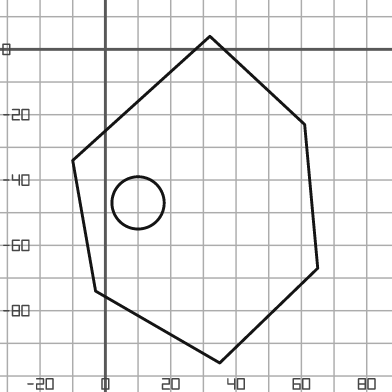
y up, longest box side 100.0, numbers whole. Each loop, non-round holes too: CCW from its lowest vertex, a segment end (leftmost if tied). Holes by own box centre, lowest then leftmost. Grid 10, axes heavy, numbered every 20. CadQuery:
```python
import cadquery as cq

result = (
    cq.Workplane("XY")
    .moveTo(35.0, -96.0)
    .lineTo(65.0, -67.0)
    .lineTo(61.0, -23.0)
    .lineTo(32.0, 4.0)
    .lineTo(-10.0, -34.0)
    .lineTo(-3.0, -74.0)
    .close()
    .moveTo(10.0, -47.0)
    .circle(8.0)
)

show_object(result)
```